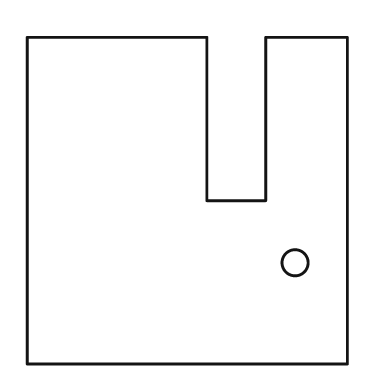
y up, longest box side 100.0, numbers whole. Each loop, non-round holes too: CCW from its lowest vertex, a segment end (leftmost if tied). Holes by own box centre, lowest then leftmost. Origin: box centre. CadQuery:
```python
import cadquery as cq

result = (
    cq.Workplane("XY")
    .moveTo(-49.0, -50.0)
    .lineTo(49.0, -50.0)
    .lineTo(49.0, 50.0)
    .lineTo(24.0, 50.0)
    .lineTo(24.0, 0.0)
    .lineTo(6.0, 0.0)
    .lineTo(6.0, 50.0)
    .lineTo(-49.0, 50.0)
    .close()
    .moveTo(33.0, -19.0)
    .circle(4.0)
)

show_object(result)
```